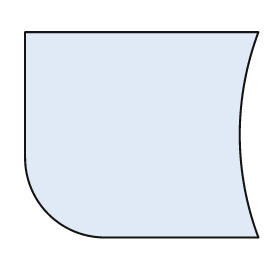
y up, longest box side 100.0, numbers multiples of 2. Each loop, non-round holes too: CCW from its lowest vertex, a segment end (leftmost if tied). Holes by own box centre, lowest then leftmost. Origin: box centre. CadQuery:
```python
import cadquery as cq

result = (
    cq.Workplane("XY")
    .moveTo(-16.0, -44.0)
    .lineTo(50.0, -44.0)
    .threePointArc((42.0, 0.0), (50.0, 44.0))
    .lineTo(-50.0, 44.0)
    .lineTo(-50.0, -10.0)
    .threePointArc((-40.0, -34.0), (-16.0, -44.0))
    .close()
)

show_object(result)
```